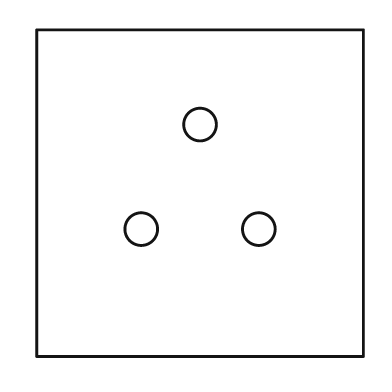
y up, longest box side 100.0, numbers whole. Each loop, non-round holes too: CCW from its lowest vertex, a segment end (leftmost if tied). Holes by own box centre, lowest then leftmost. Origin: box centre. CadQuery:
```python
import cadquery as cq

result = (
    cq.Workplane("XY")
    .moveTo(-50.0, -50.0)
    .lineTo(50.0, -50.0)
    .lineTo(50.0, 50.0)
    .lineTo(-50.0, 50.0)
    .close()
    .moveTo(-18.0, -11.0)
    .circle(5.0)
    .moveTo(18.0, -11.0)
    .circle(5.0)
    .moveTo(0.0, 21.0)
    .circle(5.0)
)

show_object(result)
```